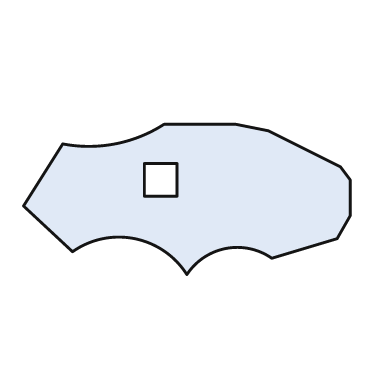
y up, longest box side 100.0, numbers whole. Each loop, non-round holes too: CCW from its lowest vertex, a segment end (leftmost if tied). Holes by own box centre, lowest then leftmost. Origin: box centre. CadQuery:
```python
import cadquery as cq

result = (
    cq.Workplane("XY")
    .moveTo(0.0, -23.0)
    .threePointArc((12.0, -15.0), (26.0, -18.0))
    .lineTo(46.0, -12.0)
    .lineTo(50.0, -5.0)
    .lineTo(50.0, 6.0)
    .lineTo(47.0, 10.0)
    .lineTo(25.0, 21.0)
    .lineTo(15.0, 23.0)
    .lineTo(-7.0, 23.0)
    .threePointArc((-22.0, 17.0), (-38.0, 17.0))
    .lineTo(-50.0, -2.0)
    .lineTo(-35.0, -16.0)
    .threePointArc((-16.0, -12.0), (0.0, -23.0))
    .close()
    .moveTo(-13.0, 1.0)
    .lineTo(-3.0, 1.0)
    .lineTo(-3.0, 11.0)
    .lineTo(-13.0, 11.0)
    .close()
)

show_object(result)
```